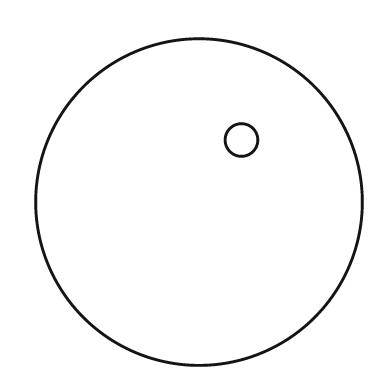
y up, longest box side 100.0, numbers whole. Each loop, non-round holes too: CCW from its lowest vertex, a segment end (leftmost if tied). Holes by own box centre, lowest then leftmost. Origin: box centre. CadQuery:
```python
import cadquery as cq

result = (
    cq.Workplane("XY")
    .moveTo(0.0, 0.0)
    .circle(50.0)
    .moveTo(13.0, 19.0)
    .circle(5.0)
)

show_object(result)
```